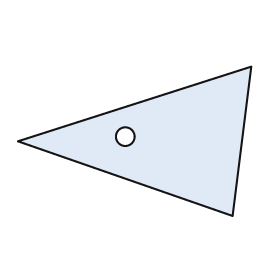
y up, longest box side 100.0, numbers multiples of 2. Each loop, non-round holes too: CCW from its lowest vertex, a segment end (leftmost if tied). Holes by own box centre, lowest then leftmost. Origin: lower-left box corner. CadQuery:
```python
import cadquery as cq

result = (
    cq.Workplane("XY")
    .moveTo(92.0, 0.0)
    .lineTo(100.0, 64.0)
    .lineTo(0.0, 32.0)
    .close()
    .moveTo(46.0, 34.0)
    .circle(4.0)
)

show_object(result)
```